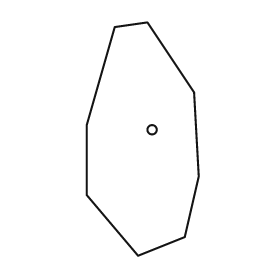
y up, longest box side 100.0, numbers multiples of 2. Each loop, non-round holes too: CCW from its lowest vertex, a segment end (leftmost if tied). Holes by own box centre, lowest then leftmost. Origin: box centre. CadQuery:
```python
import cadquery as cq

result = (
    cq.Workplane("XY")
    .moveTo(-2.0, -50.0)
    .lineTo(18.0, -42.0)
    .lineTo(24.0, -16.0)
    .lineTo(22.0, 20.0)
    .lineTo(2.0, 50.0)
    .lineTo(-12.0, 48.0)
    .lineTo(-24.0, 6.0)
    .lineTo(-24.0, -24.0)
    .close()
    .moveTo(4.0, 4.0)
    .circle(2.0)
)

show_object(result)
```